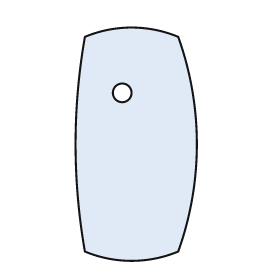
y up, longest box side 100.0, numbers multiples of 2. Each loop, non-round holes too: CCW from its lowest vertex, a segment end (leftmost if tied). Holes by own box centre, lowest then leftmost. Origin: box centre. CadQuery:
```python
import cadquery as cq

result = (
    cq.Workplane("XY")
    .moveTo(-22.0, -46.0)
    .threePointArc((-2.0, -50.0), (18.0, -46.0))
    .threePointArc((26.0, 0.0), (18.0, 46.0))
    .threePointArc((-2.0, 50.0), (-22.0, 46.0))
    .threePointArc((-26.0, 0.0), (-22.0, -46.0))
    .close()
    .moveTo(-6.0, 22.0)
    .circle(4.0)
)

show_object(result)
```